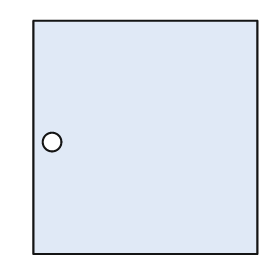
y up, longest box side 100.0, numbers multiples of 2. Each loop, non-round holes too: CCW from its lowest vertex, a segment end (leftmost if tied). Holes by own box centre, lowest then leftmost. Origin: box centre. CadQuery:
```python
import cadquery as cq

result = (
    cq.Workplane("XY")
    .moveTo(-48.0, -50.0)
    .lineTo(48.0, -50.0)
    .lineTo(48.0, 50.0)
    .lineTo(-48.0, 50.0)
    .close()
    .moveTo(-40.0, -2.0)
    .circle(4.0)
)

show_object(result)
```